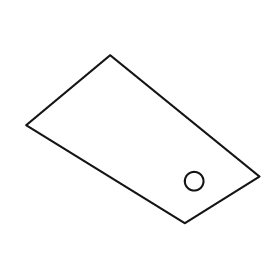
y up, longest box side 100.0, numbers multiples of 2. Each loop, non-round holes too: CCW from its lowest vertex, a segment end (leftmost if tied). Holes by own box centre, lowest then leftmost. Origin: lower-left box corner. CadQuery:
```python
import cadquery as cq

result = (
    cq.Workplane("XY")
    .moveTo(68.0, 0.0)
    .lineTo(100.0, 20.0)
    .lineTo(36.0, 72.0)
    .lineTo(0.0, 42.0)
    .close()
    .moveTo(72.0, 18.0)
    .circle(4.0)
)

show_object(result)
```